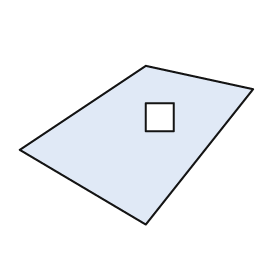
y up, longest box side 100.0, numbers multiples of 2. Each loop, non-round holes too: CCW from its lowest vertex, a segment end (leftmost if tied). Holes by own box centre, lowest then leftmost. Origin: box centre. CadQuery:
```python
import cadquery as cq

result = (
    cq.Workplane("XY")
    .moveTo(4.0, -34.0)
    .lineTo(50.0, 24.0)
    .lineTo(4.0, 34.0)
    .lineTo(-50.0, -2.0)
    .close()
    .moveTo(4.0, 6.0)
    .lineTo(16.0, 6.0)
    .lineTo(16.0, 18.0)
    .lineTo(4.0, 18.0)
    .close()
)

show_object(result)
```